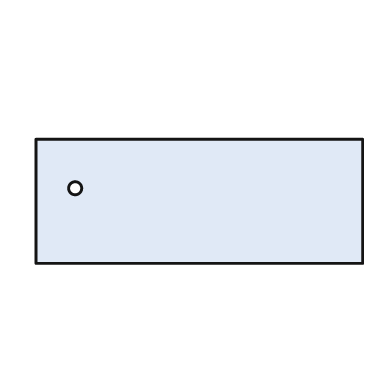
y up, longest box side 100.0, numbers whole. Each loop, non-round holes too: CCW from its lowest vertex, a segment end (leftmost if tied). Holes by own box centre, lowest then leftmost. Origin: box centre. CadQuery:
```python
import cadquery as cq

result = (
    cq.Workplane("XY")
    .moveTo(-50.0, -19.0)
    .lineTo(50.0, -19.0)
    .lineTo(50.0, 19.0)
    .lineTo(-50.0, 19.0)
    .close()
    .moveTo(-38.0, 4.0)
    .circle(2.0)
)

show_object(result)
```